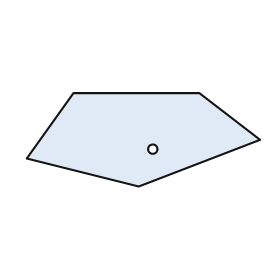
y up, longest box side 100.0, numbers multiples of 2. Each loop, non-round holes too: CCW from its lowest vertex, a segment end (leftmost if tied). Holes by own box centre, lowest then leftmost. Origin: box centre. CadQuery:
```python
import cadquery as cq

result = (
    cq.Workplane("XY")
    .moveTo(-2.0, -20.0)
    .lineTo(50.0, 0.0)
    .lineTo(24.0, 20.0)
    .lineTo(-30.0, 20.0)
    .lineTo(-50.0, -8.0)
    .close()
    .moveTo(4.0, -4.0)
    .circle(2.0)
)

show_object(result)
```